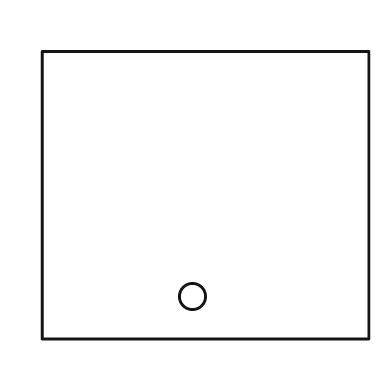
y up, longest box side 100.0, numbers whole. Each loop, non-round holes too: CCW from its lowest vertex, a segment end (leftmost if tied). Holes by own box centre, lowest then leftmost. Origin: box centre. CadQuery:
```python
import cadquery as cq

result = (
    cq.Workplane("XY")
    .moveTo(-50.0, -44.0)
    .lineTo(50.0, -44.0)
    .lineTo(50.0, 44.0)
    .lineTo(-50.0, 44.0)
    .close()
    .moveTo(-4.0, -31.0)
    .circle(4.0)
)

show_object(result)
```